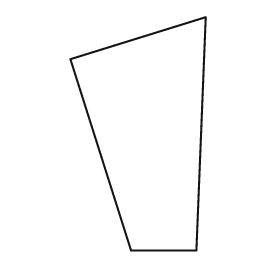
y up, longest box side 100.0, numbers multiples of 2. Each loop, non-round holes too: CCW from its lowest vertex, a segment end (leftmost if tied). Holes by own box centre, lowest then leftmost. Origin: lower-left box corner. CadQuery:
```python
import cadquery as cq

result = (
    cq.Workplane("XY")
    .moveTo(26.0, 0.0)
    .lineTo(54.0, 0.0)
    .lineTo(58.0, 100.0)
    .lineTo(0.0, 82.0)
    .close()
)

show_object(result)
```